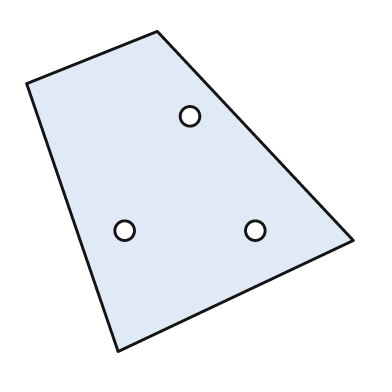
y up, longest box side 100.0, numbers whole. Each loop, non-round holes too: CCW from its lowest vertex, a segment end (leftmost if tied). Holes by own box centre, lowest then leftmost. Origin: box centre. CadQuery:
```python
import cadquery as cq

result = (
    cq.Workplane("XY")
    .moveTo(-22.0, -49.0)
    .lineTo(50.0, -15.0)
    .lineTo(-10.0, 49.0)
    .lineTo(-50.0, 33.0)
    .close()
    .moveTo(-20.0, -12.0)
    .circle(3.0)
    .moveTo(20.0, -12.0)
    .circle(3.0)
    .moveTo(0.0, 23.0)
    .circle(3.0)
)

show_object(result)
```